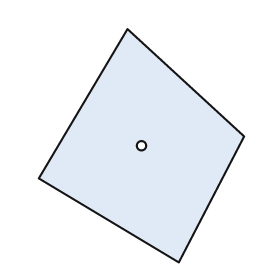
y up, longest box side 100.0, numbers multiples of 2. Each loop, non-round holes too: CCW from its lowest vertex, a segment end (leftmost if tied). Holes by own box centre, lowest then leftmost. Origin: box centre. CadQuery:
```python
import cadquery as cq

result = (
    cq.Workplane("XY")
    .moveTo(16.0, -50.0)
    .lineTo(44.0, 4.0)
    .lineTo(-6.0, 50.0)
    .lineTo(-44.0, -14.0)
    .close()
    .moveTo(0.0, 0.0)
    .circle(2.0)
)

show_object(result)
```